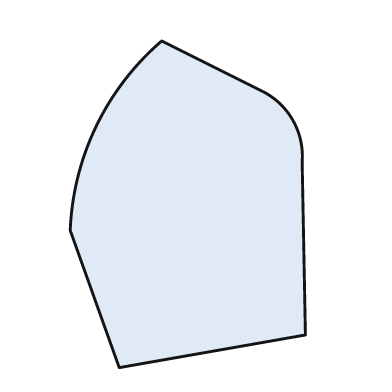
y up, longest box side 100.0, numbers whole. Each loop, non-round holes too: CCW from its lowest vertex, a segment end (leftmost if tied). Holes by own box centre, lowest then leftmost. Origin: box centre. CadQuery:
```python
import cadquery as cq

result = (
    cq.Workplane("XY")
    .moveTo(-21.0, -50.0)
    .lineTo(36.0, -40.0)
    .lineTo(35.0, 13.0)
    .threePointArc((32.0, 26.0), (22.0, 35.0))
    .lineTo(-8.0, 50.0)
    .threePointArc((-28.0, 24.0), (-36.0, -8.0))
    .close()
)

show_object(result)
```